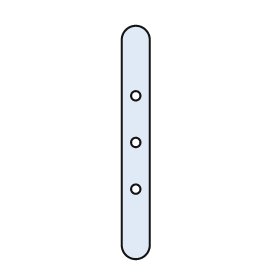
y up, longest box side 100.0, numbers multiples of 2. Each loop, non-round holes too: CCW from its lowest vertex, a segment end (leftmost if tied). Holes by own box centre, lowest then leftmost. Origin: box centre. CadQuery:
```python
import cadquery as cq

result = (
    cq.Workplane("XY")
    .moveTo(-6.0, -44.0)
    .threePointArc((0.0, -50.0), (6.0, -44.0))
    .lineTo(6.0, 44.0)
    .threePointArc((0.0, 50.0), (-6.0, 44.0))
    .close()
    .moveTo(0.0, -20.0)
    .circle(2.0)
    .moveTo(0.0, 0.0)
    .circle(2.0)
    .moveTo(0.0, 20.0)
    .circle(2.0)
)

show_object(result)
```